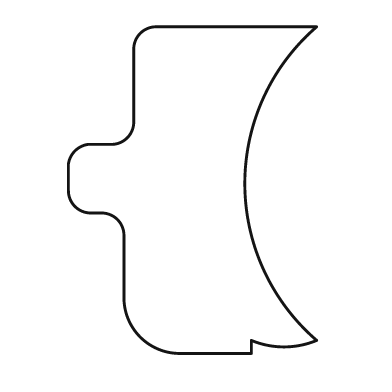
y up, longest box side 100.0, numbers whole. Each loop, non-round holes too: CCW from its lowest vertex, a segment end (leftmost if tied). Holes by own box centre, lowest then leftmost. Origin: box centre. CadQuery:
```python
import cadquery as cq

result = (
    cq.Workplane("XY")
    .moveTo(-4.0, -50.0)
    .lineTo(18.0, -50.0)
    .lineTo(18.0, -46.0)
    .threePointArc((28.0, -48.0), (38.0, -46.0))
    .threePointArc((16.0, 2.0), (38.0, 50.0))
    .lineTo(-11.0, 50.0)
    .threePointArc((-16.0, 48.0), (-18.0, 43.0))
    .lineTo(-18.0, 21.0)
    .threePointArc((-20.0, 16.0), (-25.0, 14.0))
    .lineTo(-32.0, 14.0)
    .threePointArc((-36.0, 12.0), (-38.0, 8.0))
    .lineTo(-38.0, 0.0)
    .threePointArc((-36.0, -5.0), (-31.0, -7.0))
    .lineTo(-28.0, -7.0)
    .threePointArc((-23.0, -9.0), (-21.0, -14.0))
    .lineTo(-21.0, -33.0)
    .threePointArc((-16.0, -45.0), (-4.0, -50.0))
    .close()
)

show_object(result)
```